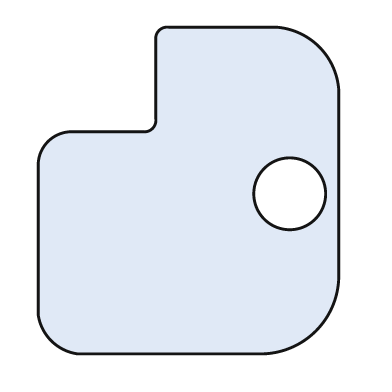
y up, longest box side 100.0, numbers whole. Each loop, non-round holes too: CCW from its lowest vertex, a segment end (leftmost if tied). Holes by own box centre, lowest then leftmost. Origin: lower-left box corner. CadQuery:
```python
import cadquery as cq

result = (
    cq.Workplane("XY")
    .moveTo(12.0, 0.0)
    .lineTo(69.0, 0.0)
    .threePointArc((85.0, 7.0), (92.0, 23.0))
    .lineTo(92.0, 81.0)
    .threePointArc((86.0, 94.0), (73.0, 100.0))
    .lineTo(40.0, 100.0)
    .threePointArc((37.0, 99.0), (36.0, 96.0))
    .lineTo(36.0, 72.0)
    .threePointArc((35.0, 69.0), (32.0, 68.0))
    .lineTo(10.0, 68.0)
    .threePointArc((3.0, 65.0), (0.0, 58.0))
    .lineTo(0.0, 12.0)
    .threePointArc((4.0, 4.0), (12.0, 0.0))
    .close()
    .moveTo(77.0, 49.0)
    .circle(11.0)
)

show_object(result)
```